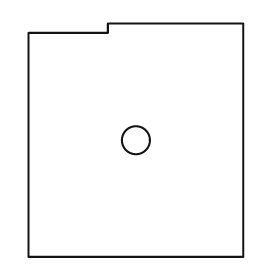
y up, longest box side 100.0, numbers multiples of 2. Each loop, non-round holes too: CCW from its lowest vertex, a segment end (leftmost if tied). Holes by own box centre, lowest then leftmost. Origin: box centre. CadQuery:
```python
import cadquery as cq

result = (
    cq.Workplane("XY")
    .moveTo(-46.0, -50.0)
    .lineTo(46.0, -50.0)
    .lineTo(46.0, 50.0)
    .lineTo(-12.0, 50.0)
    .lineTo(-12.0, 46.0)
    .lineTo(-46.0, 46.0)
    .close()
    .moveTo(0.0, 0.0)
    .circle(6.0)
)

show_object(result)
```